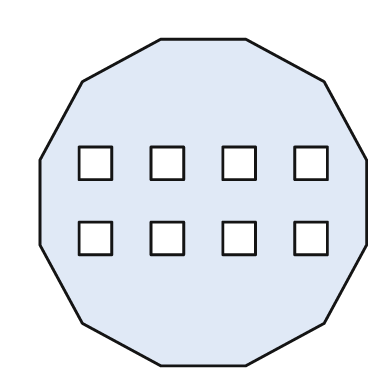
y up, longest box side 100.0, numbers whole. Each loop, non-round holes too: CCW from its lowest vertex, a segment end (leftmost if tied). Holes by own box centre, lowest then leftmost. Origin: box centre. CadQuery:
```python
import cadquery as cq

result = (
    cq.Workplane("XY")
    .moveTo(-13.0, -50.0)
    .lineTo(13.0, -50.0)
    .lineTo(37.0, -37.0)
    .lineTo(50.0, -13.0)
    .lineTo(50.0, 13.0)
    .lineTo(37.0, 37.0)
    .lineTo(13.0, 50.0)
    .lineTo(-13.0, 50.0)
    .lineTo(-37.0, 37.0)
    .lineTo(-50.0, 13.0)
    .lineTo(-50.0, -13.0)
    .lineTo(-37.0, -37.0)
    .close()
    .moveTo(-38.0, -16.0)
    .lineTo(-28.0, -16.0)
    .lineTo(-28.0, -6.0)
    .lineTo(-38.0, -6.0)
    .close()
    .moveTo(-16.0, -16.0)
    .lineTo(-6.0, -16.0)
    .lineTo(-6.0, -6.0)
    .lineTo(-16.0, -6.0)
    .close()
    .moveTo(6.0, -16.0)
    .lineTo(16.0, -16.0)
    .lineTo(16.0, -6.0)
    .lineTo(6.0, -6.0)
    .close()
    .moveTo(28.0, -16.0)
    .lineTo(38.0, -16.0)
    .lineTo(38.0, -6.0)
    .lineTo(28.0, -6.0)
    .close()
    .moveTo(-38.0, 7.0)
    .lineTo(-28.0, 7.0)
    .lineTo(-28.0, 17.0)
    .lineTo(-38.0, 17.0)
    .close()
    .moveTo(-16.0, 7.0)
    .lineTo(-6.0, 7.0)
    .lineTo(-6.0, 17.0)
    .lineTo(-16.0, 17.0)
    .close()
    .moveTo(6.0, 7.0)
    .lineTo(16.0, 7.0)
    .lineTo(16.0, 17.0)
    .lineTo(6.0, 17.0)
    .close()
    .moveTo(28.0, 7.0)
    .lineTo(38.0, 7.0)
    .lineTo(38.0, 17.0)
    .lineTo(28.0, 17.0)
    .close()
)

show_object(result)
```